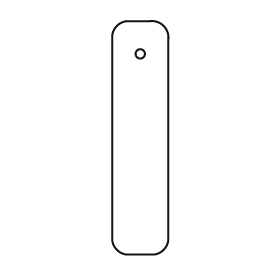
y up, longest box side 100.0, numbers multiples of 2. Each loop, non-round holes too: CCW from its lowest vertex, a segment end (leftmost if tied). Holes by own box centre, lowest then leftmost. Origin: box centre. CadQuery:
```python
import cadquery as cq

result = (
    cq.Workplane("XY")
    .moveTo(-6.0, -50.0)
    .lineTo(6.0, -50.0)
    .threePointArc((10.0, -48.0), (12.0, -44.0))
    .lineTo(12.0, 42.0)
    .threePointArc((10.0, 48.0), (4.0, 50.0))
    .lineTo(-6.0, 50.0)
    .threePointArc((-10.0, 48.0), (-12.0, 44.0))
    .lineTo(-12.0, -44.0)
    .threePointArc((-10.0, -48.0), (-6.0, -50.0))
    .close()
    .moveTo(0.0, 36.0)
    .circle(2.0)
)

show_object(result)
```